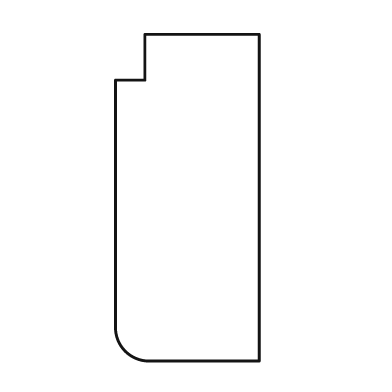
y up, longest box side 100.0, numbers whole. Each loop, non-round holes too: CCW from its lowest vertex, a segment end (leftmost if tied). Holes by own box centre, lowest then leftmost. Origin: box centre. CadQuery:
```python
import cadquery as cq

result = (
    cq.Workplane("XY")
    .moveTo(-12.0, -50.0)
    .lineTo(22.0, -50.0)
    .lineTo(22.0, 50.0)
    .lineTo(-13.0, 50.0)
    .lineTo(-13.0, 36.0)
    .lineTo(-22.0, 36.0)
    .lineTo(-22.0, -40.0)
    .threePointArc((-19.0, -47.0), (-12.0, -50.0))
    .close()
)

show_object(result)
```